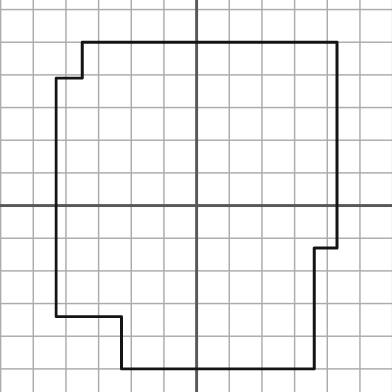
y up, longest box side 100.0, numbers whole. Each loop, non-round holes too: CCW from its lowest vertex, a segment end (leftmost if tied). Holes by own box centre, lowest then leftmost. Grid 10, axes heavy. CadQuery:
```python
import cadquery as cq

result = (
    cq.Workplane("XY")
    .moveTo(-23.0, -50.0)
    .lineTo(36.0, -50.0)
    .lineTo(36.0, -13.0)
    .lineTo(43.0, -13.0)
    .lineTo(43.0, 50.0)
    .lineTo(-35.0, 50.0)
    .lineTo(-35.0, 39.0)
    .lineTo(-43.0, 39.0)
    .lineTo(-43.0, -34.0)
    .lineTo(-23.0, -34.0)
    .close()
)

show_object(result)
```